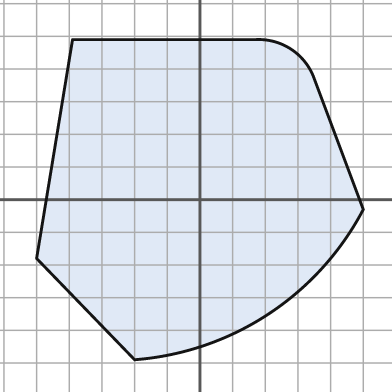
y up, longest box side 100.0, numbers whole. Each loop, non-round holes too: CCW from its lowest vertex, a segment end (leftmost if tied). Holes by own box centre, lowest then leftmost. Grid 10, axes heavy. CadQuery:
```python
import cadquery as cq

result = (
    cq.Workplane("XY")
    .moveTo(-20.0, -49.0)
    .threePointArc((21.0, -35.0), (50.0, -3.0))
    .lineTo(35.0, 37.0)
    .threePointArc((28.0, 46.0), (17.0, 49.0))
    .lineTo(-39.0, 49.0)
    .lineTo(-50.0, -18.0)
    .close()
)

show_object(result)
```